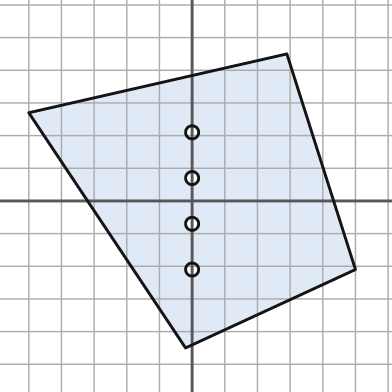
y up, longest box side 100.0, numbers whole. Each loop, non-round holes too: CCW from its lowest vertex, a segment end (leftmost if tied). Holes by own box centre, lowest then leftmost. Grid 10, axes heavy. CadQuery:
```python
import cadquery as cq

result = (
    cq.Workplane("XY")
    .moveTo(-2.0, -45.0)
    .lineTo(50.0, -21.0)
    .lineTo(29.0, 45.0)
    .lineTo(-50.0, 27.0)
    .close()
    .moveTo(0.0, -21.0)
    .circle(2.0)
    .moveTo(0.0, -7.0)
    .circle(2.0)
    .moveTo(0.0, 7.0)
    .circle(2.0)
    .moveTo(0.0, 21.0)
    .circle(2.0)
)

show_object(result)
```